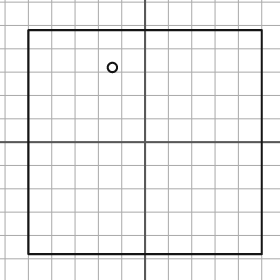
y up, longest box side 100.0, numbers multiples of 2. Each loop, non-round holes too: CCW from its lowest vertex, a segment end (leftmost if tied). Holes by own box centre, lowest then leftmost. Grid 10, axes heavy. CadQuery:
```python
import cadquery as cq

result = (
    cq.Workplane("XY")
    .moveTo(-50.0, -48.0)
    .lineTo(50.0, -48.0)
    .lineTo(50.0, 48.0)
    .lineTo(-50.0, 48.0)
    .close()
    .moveTo(-14.0, 32.0)
    .circle(2.0)
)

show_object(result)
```